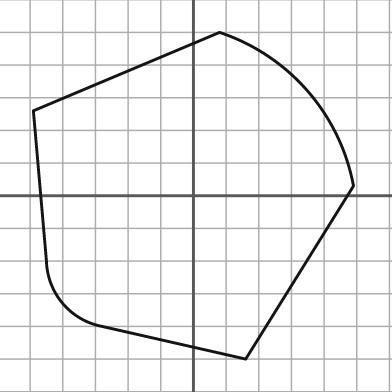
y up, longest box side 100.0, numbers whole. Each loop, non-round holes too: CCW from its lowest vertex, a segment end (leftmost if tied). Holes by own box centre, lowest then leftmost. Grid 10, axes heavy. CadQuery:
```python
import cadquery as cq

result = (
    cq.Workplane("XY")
    .moveTo(16.0, -50.0)
    .lineTo(49.0, 3.0)
    .threePointArc((35.0, 32.0), (8.0, 50.0))
    .lineTo(-49.0, 26.0)
    .lineTo(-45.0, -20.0)
    .threePointArc((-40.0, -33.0), (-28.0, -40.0))
    .close()
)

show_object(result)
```